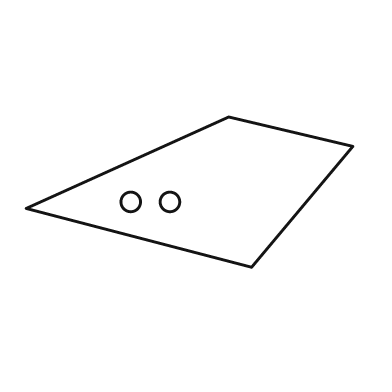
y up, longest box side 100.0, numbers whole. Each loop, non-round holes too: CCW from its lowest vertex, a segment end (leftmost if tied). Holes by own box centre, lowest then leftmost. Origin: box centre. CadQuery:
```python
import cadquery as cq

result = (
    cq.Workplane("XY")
    .moveTo(19.0, -23.0)
    .lineTo(50.0, 14.0)
    .lineTo(12.0, 23.0)
    .lineTo(-50.0, -5.0)
    .close()
    .moveTo(-18.0, -3.0)
    .circle(3.0)
    .moveTo(-6.0, -3.0)
    .circle(3.0)
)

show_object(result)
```